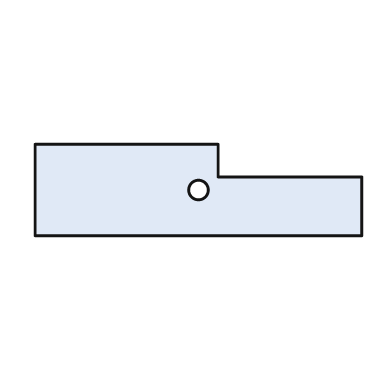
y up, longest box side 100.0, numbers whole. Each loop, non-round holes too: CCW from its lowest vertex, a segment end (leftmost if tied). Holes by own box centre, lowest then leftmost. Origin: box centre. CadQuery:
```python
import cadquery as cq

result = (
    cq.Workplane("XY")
    .moveTo(-50.0, -14.0)
    .lineTo(50.0, -14.0)
    .lineTo(50.0, 4.0)
    .lineTo(6.0, 4.0)
    .lineTo(6.0, 14.0)
    .lineTo(-50.0, 14.0)
    .close()
    .moveTo(0.0, 0.0)
    .circle(3.0)
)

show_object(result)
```